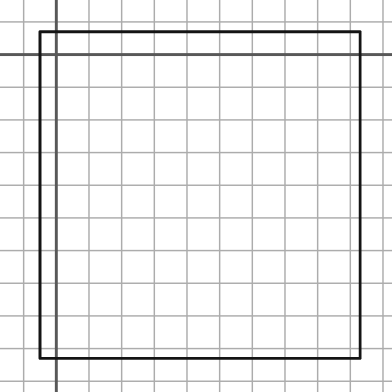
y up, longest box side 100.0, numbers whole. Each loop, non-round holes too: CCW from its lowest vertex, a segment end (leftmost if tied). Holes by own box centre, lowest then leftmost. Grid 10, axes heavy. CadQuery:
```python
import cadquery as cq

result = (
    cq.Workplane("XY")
    .moveTo(-5.0, -93.0)
    .lineTo(93.0, -93.0)
    .lineTo(93.0, 7.0)
    .lineTo(-5.0, 7.0)
    .close()
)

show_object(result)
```